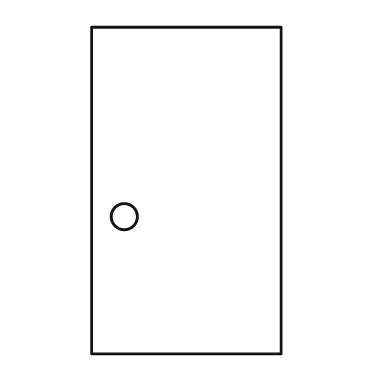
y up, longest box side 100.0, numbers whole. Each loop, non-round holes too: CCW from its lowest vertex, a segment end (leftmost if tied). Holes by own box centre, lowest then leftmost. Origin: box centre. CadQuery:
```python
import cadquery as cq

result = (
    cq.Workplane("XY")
    .moveTo(-29.0, -50.0)
    .lineTo(29.0, -50.0)
    .lineTo(29.0, 50.0)
    .lineTo(-29.0, 50.0)
    .close()
    .moveTo(-19.0, -8.0)
    .circle(4.0)
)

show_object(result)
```